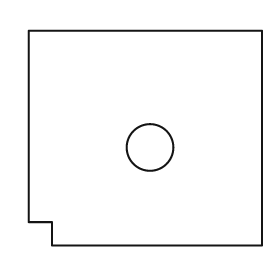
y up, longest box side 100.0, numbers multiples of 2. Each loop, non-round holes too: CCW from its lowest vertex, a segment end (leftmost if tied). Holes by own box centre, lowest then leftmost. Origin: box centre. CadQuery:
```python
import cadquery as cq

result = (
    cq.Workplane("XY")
    .moveTo(-40.0, -46.0)
    .lineTo(50.0, -46.0)
    .lineTo(50.0, 46.0)
    .lineTo(-50.0, 46.0)
    .lineTo(-50.0, -36.0)
    .lineTo(-40.0, -36.0)
    .close()
    .moveTo(2.0, -4.0)
    .circle(10.0)
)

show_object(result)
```